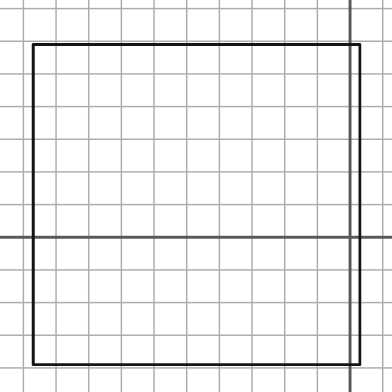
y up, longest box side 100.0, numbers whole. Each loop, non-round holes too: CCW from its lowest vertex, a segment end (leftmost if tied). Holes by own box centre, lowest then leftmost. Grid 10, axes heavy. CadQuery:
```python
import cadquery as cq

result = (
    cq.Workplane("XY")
    .moveTo(-97.0, -39.0)
    .lineTo(3.0, -39.0)
    .lineTo(3.0, 59.0)
    .lineTo(-97.0, 59.0)
    .close()
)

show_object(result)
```